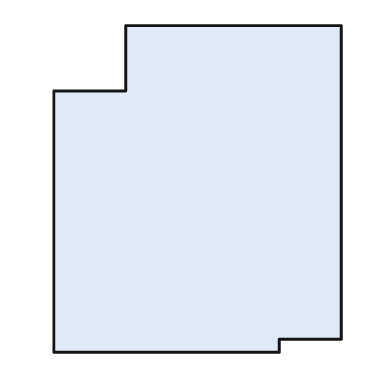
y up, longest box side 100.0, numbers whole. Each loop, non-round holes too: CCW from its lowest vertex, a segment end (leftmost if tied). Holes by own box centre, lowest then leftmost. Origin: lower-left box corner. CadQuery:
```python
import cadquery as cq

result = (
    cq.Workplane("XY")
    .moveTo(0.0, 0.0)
    .lineTo(69.0, 0.0)
    .lineTo(69.0, 4.0)
    .lineTo(88.0, 4.0)
    .lineTo(88.0, 100.0)
    .lineTo(22.0, 100.0)
    .lineTo(22.0, 80.0)
    .lineTo(0.0, 80.0)
    .close()
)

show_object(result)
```